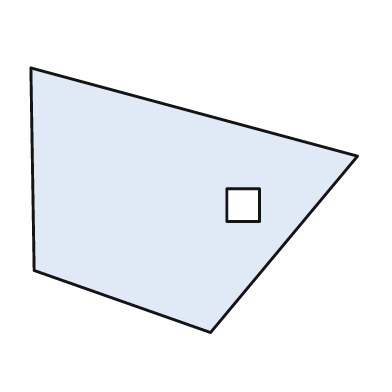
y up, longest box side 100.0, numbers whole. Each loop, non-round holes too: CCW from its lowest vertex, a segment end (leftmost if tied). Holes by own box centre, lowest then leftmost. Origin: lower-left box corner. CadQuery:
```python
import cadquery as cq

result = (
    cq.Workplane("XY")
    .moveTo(55.0, 0.0)
    .lineTo(100.0, 54.0)
    .lineTo(0.0, 81.0)
    .lineTo(1.0, 19.0)
    .close()
    .moveTo(60.0, 34.0)
    .lineTo(70.0, 34.0)
    .lineTo(70.0, 44.0)
    .lineTo(60.0, 44.0)
    .close()
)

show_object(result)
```